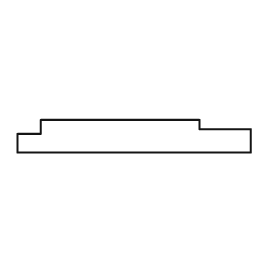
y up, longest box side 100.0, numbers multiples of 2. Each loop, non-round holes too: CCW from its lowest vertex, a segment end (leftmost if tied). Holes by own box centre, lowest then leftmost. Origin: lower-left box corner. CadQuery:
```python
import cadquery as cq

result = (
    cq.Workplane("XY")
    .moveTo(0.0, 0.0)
    .lineTo(100.0, 0.0)
    .lineTo(100.0, 10.0)
    .lineTo(78.0, 10.0)
    .lineTo(78.0, 14.0)
    .lineTo(10.0, 14.0)
    .lineTo(10.0, 8.0)
    .lineTo(0.0, 8.0)
    .close()
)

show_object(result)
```